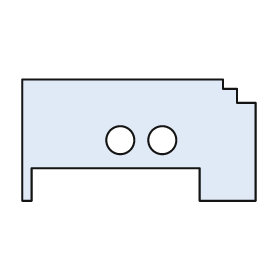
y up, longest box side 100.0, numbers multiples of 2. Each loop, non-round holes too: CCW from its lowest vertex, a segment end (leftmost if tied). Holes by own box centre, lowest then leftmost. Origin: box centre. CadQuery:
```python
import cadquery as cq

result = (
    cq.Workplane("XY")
    .moveTo(-50.0, -26.0)
    .lineTo(-46.0, -26.0)
    .lineTo(-46.0, -12.0)
    .lineTo(26.0, -12.0)
    .lineTo(26.0, -26.0)
    .lineTo(50.0, -26.0)
    .lineTo(50.0, 16.0)
    .lineTo(42.0, 16.0)
    .lineTo(42.0, 22.0)
    .lineTo(36.0, 22.0)
    .lineTo(36.0, 26.0)
    .lineTo(-50.0, 26.0)
    .close()
    .moveTo(-8.0, 0.0)
    .circle(6.0)
    .moveTo(10.0, 0.0)
    .circle(6.0)
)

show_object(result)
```